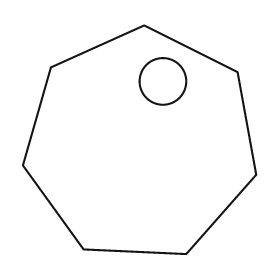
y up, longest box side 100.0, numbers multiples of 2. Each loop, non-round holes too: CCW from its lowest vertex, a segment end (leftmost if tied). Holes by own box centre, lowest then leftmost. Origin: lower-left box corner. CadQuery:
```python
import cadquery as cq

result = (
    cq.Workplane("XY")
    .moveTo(70.0, 0.0)
    .lineTo(100.0, 34.0)
    .lineTo(92.0, 78.0)
    .lineTo(52.0, 98.0)
    .lineTo(12.0, 80.0)
    .lineTo(0.0, 38.0)
    .lineTo(26.0, 2.0)
    .close()
    .moveTo(60.0, 74.0)
    .circle(10.0)
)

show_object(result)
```